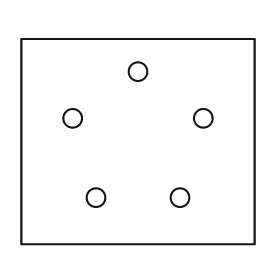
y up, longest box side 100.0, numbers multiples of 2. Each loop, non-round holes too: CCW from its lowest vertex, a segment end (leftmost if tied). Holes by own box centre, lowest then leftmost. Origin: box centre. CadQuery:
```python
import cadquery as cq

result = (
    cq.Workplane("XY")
    .moveTo(-50.0, -44.0)
    .lineTo(50.0, -44.0)
    .lineTo(50.0, 44.0)
    .lineTo(-50.0, 44.0)
    .close()
    .moveTo(-18.0, -24.0)
    .circle(4.0)
    .moveTo(18.0, -24.0)
    .circle(4.0)
    .moveTo(-28.0, 10.0)
    .circle(4.0)
    .moveTo(28.0, 10.0)
    .circle(4.0)
    .moveTo(0.0, 30.0)
    .circle(4.0)
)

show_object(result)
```